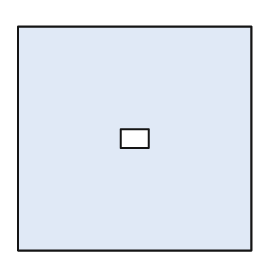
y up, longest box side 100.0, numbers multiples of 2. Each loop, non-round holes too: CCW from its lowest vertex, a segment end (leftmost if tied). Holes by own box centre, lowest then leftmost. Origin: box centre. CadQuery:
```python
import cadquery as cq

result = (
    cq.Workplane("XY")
    .moveTo(-50.0, -48.0)
    .lineTo(50.0, -48.0)
    .lineTo(50.0, 48.0)
    .lineTo(-50.0, 48.0)
    .close()
    .moveTo(-6.0, -4.0)
    .lineTo(6.0, -4.0)
    .lineTo(6.0, 4.0)
    .lineTo(-6.0, 4.0)
    .close()
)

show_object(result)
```